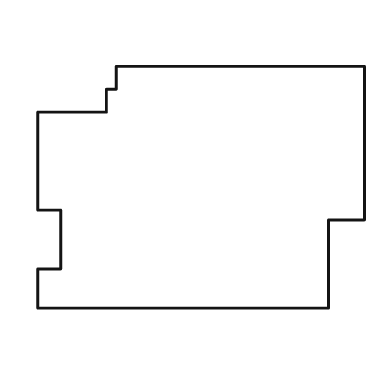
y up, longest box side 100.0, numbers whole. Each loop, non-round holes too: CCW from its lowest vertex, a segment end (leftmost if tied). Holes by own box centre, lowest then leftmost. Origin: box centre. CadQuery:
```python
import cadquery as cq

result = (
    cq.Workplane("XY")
    .moveTo(-50.0, -37.0)
    .lineTo(39.0, -37.0)
    .lineTo(39.0, -10.0)
    .lineTo(50.0, -10.0)
    .lineTo(50.0, 37.0)
    .lineTo(-26.0, 37.0)
    .lineTo(-26.0, 30.0)
    .lineTo(-29.0, 30.0)
    .lineTo(-29.0, 23.0)
    .lineTo(-50.0, 23.0)
    .lineTo(-50.0, -7.0)
    .lineTo(-43.0, -7.0)
    .lineTo(-43.0, -25.0)
    .lineTo(-50.0, -25.0)
    .close()
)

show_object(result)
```